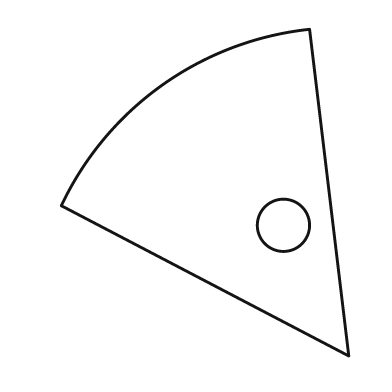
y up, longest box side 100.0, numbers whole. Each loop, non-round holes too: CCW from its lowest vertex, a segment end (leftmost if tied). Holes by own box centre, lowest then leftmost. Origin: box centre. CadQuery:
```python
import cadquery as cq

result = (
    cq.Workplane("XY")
    .moveTo(44.0, -50.0)
    .lineTo(32.0, 50.0)
    .threePointArc((-13.0, 33.0), (-44.0, -4.0))
    .close()
    .moveTo(24.0, -10.0)
    .circle(8.0)
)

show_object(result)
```